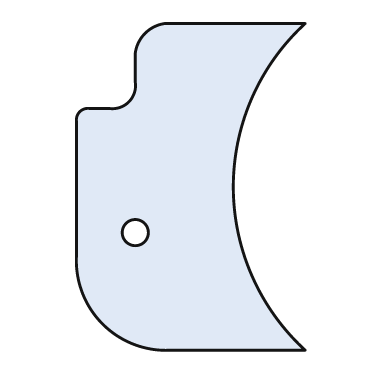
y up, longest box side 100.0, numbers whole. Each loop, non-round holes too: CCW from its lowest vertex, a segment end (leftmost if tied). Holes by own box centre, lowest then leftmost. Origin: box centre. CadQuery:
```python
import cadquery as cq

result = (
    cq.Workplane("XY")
    .moveTo(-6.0, -50.0)
    .lineTo(35.0, -50.0)
    .threePointArc((13.0, 0.0), (35.0, 50.0))
    .lineTo(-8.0, 50.0)
    .threePointArc((-14.0, 47.0), (-17.0, 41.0))
    .lineTo(-17.0, 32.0)
    .threePointArc((-19.0, 26.0), (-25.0, 24.0))
    .lineTo(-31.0, 24.0)
    .threePointArc((-34.0, 23.0), (-35.0, 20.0))
    .lineTo(-35.0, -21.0)
    .threePointArc((-27.0, -42.0), (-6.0, -50.0))
    .close()
    .moveTo(-17.0, -14.0)
    .circle(4.0)
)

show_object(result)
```